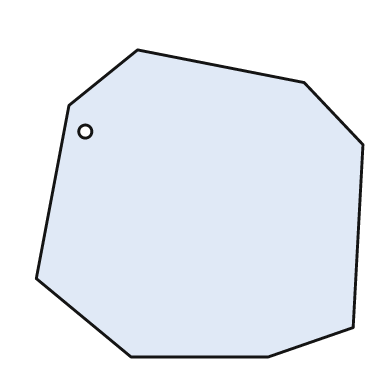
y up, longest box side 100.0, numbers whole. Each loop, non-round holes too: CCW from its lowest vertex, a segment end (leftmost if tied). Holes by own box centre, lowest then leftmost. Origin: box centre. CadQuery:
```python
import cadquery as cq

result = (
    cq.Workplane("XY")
    .moveTo(-21.0, -47.0)
    .lineTo(21.0, -47.0)
    .lineTo(47.0, -38.0)
    .lineTo(50.0, 18.0)
    .lineTo(32.0, 37.0)
    .lineTo(-19.0, 47.0)
    .lineTo(-40.0, 30.0)
    .lineTo(-50.0, -23.0)
    .close()
    .moveTo(-35.0, 22.0)
    .circle(2.0)
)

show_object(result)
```